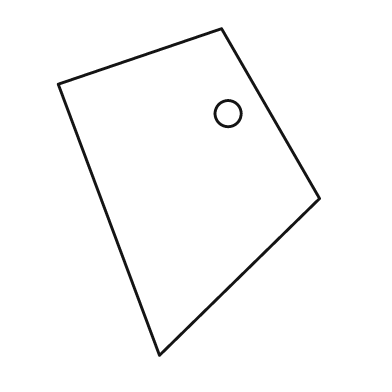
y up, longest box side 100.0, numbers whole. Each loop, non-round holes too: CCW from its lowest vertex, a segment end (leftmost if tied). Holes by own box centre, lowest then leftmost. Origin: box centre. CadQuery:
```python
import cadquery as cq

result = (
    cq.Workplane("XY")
    .moveTo(-9.0, -50.0)
    .lineTo(40.0, -2.0)
    .lineTo(10.0, 50.0)
    .lineTo(-40.0, 33.0)
    .close()
    .moveTo(12.0, 24.0)
    .circle(4.0)
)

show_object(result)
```